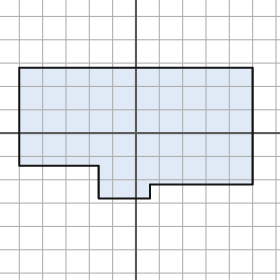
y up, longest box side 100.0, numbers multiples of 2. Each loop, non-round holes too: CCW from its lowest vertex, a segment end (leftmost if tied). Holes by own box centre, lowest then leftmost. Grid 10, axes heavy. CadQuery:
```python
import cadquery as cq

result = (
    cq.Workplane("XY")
    .moveTo(-16.0, -28.0)
    .lineTo(6.0, -28.0)
    .lineTo(6.0, -22.0)
    .lineTo(50.0, -22.0)
    .lineTo(50.0, 28.0)
    .lineTo(-50.0, 28.0)
    .lineTo(-50.0, -14.0)
    .lineTo(-16.0, -14.0)
    .close()
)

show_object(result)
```